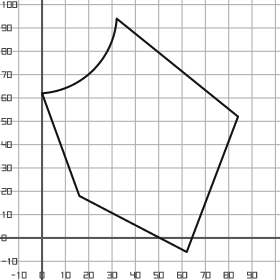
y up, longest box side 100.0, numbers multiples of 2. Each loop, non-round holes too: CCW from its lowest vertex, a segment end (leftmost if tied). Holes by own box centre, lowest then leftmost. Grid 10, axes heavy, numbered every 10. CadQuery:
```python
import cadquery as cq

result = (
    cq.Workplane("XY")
    .moveTo(62.0, -6.0)
    .lineTo(84.0, 52.0)
    .lineTo(32.0, 94.0)
    .threePointArc((22.0, 72.0), (0.0, 62.0))
    .lineTo(16.0, 18.0)
    .close()
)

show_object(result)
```